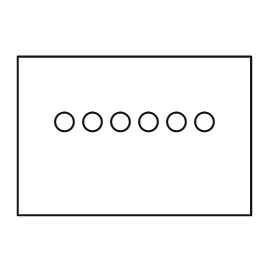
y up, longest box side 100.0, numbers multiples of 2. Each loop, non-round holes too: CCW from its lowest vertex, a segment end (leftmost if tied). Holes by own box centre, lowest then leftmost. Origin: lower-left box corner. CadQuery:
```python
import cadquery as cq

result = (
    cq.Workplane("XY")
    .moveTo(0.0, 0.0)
    .lineTo(100.0, 0.0)
    .lineTo(100.0, 68.0)
    .lineTo(0.0, 68.0)
    .close()
    .moveTo(20.0, 40.0)
    .circle(4.0)
    .moveTo(32.0, 40.0)
    .circle(4.0)
    .moveTo(44.0, 40.0)
    .circle(4.0)
    .moveTo(56.0, 40.0)
    .circle(4.0)
    .moveTo(68.0, 40.0)
    .circle(4.0)
    .moveTo(80.0, 40.0)
    .circle(4.0)
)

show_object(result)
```